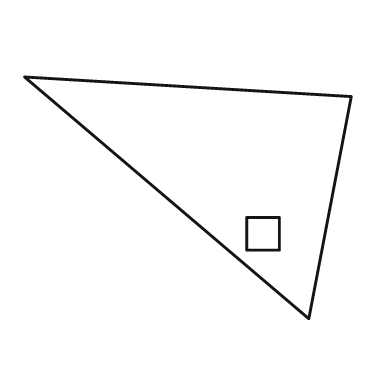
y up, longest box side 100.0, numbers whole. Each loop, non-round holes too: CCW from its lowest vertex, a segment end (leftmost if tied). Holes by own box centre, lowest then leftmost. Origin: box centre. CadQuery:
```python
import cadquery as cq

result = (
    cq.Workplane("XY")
    .moveTo(37.0, -37.0)
    .lineTo(50.0, 31.0)
    .lineTo(-50.0, 37.0)
    .close()
    .moveTo(18.0, -16.0)
    .lineTo(28.0, -16.0)
    .lineTo(28.0, -6.0)
    .lineTo(18.0, -6.0)
    .close()
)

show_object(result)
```